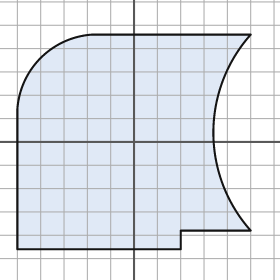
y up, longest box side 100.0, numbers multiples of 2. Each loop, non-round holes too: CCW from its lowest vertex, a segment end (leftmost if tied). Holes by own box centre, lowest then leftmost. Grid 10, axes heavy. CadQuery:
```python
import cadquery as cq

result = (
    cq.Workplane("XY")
    .moveTo(-50.0, -46.0)
    .lineTo(20.0, -46.0)
    .lineTo(20.0, -38.0)
    .lineTo(50.0, -38.0)
    .threePointArc((34.0, 4.0), (50.0, 46.0))
    .lineTo(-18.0, 46.0)
    .threePointArc((-40.0, 36.0), (-50.0, 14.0))
    .close()
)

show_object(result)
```